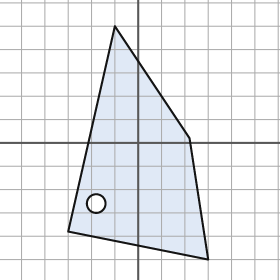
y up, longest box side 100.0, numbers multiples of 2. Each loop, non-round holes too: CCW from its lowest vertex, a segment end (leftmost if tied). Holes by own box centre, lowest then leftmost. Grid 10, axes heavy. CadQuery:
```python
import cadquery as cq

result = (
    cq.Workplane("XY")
    .moveTo(30.0, -50.0)
    .lineTo(22.0, 2.0)
    .lineTo(-10.0, 50.0)
    .lineTo(-30.0, -38.0)
    .close()
    .moveTo(-18.0, -26.0)
    .circle(4.0)
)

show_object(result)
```